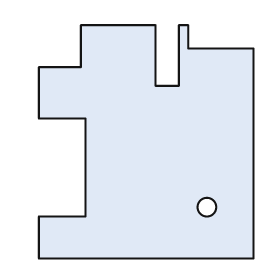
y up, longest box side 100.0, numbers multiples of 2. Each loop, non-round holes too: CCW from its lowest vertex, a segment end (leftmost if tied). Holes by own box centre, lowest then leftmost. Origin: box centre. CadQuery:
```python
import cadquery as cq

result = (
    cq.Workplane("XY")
    .moveTo(-46.0, -50.0)
    .lineTo(46.0, -50.0)
    .lineTo(46.0, 40.0)
    .lineTo(18.0, 40.0)
    .lineTo(18.0, 50.0)
    .lineTo(14.0, 50.0)
    .lineTo(14.0, 24.0)
    .lineTo(4.0, 24.0)
    .lineTo(4.0, 50.0)
    .lineTo(-28.0, 50.0)
    .lineTo(-28.0, 32.0)
    .lineTo(-46.0, 32.0)
    .lineTo(-46.0, 10.0)
    .lineTo(-26.0, 10.0)
    .lineTo(-26.0, -32.0)
    .lineTo(-46.0, -32.0)
    .close()
    .moveTo(26.0, -28.0)
    .circle(4.0)
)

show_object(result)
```